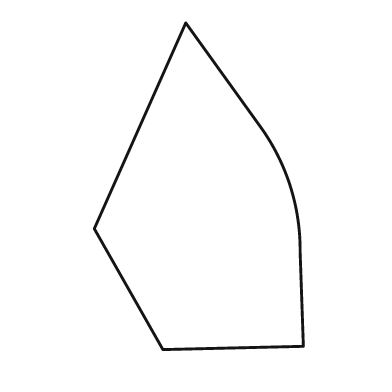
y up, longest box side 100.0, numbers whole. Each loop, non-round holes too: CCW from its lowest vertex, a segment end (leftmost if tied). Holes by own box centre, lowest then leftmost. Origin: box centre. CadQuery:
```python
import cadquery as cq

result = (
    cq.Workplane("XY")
    .moveTo(-11.0, -50.0)
    .lineTo(32.0, -49.0)
    .lineTo(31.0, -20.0)
    .threePointArc((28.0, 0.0), (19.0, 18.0))
    .lineTo(-4.0, 50.0)
    .lineTo(-32.0, -13.0)
    .close()
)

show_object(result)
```